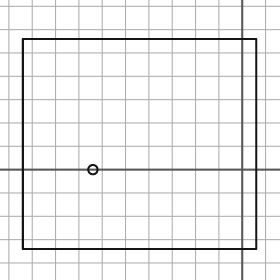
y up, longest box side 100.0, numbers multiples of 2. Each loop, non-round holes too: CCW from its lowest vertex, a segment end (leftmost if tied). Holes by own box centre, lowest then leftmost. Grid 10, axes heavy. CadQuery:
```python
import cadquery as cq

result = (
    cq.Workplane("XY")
    .moveTo(-94.0, -34.0)
    .lineTo(6.0, -34.0)
    .lineTo(6.0, 56.0)
    .lineTo(-94.0, 56.0)
    .close()
    .moveTo(-64.0, 0.0)
    .circle(2.0)
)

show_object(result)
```